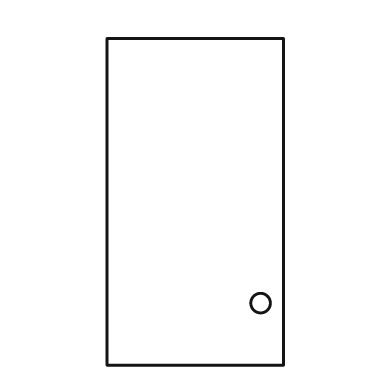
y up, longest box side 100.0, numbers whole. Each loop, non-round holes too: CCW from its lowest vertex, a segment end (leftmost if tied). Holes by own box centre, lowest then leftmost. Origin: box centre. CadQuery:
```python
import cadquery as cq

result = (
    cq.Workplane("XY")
    .moveTo(-27.0, -50.0)
    .lineTo(27.0, -50.0)
    .lineTo(27.0, 50.0)
    .lineTo(-27.0, 50.0)
    .close()
    .moveTo(20.0, -31.0)
    .circle(3.0)
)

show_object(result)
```